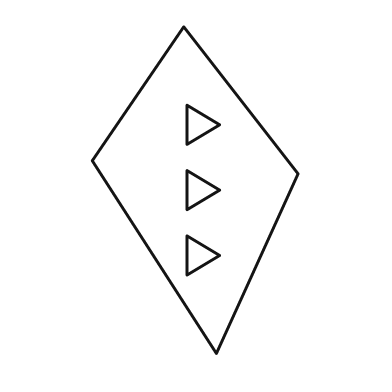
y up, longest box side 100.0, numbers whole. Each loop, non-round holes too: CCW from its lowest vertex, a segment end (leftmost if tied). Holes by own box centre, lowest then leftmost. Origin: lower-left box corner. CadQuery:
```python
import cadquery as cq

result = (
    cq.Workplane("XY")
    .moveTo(38.0, 0.0)
    .lineTo(63.0, 55.0)
    .lineTo(28.0, 100.0)
    .lineTo(0.0, 59.0)
    .close()
    .moveTo(29.0, 24.0)
    .lineTo(39.0, 30.0)
    .lineTo(29.0, 36.0)
    .close()
    .moveTo(29.0, 44.0)
    .lineTo(39.0, 50.0)
    .lineTo(29.0, 56.0)
    .close()
    .moveTo(29.0, 64.0)
    .lineTo(39.0, 70.0)
    .lineTo(29.0, 76.0)
    .close()
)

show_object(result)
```